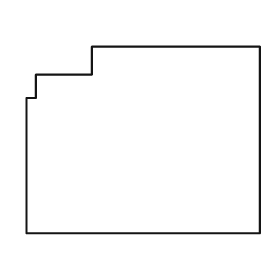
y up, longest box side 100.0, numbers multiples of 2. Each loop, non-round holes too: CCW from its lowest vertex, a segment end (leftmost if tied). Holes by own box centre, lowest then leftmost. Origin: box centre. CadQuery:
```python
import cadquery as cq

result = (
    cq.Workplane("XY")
    .moveTo(-50.0, -40.0)
    .lineTo(50.0, -40.0)
    .lineTo(50.0, 40.0)
    .lineTo(-22.0, 40.0)
    .lineTo(-22.0, 28.0)
    .lineTo(-46.0, 28.0)
    .lineTo(-46.0, 18.0)
    .lineTo(-50.0, 18.0)
    .close()
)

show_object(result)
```